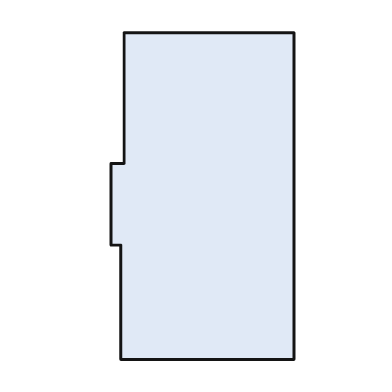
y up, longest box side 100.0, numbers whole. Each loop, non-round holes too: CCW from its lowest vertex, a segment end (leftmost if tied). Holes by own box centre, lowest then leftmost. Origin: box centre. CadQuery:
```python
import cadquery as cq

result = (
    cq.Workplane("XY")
    .moveTo(-25.0, -50.0)
    .lineTo(28.0, -50.0)
    .lineTo(28.0, 50.0)
    .lineTo(-24.0, 50.0)
    .lineTo(-24.0, 10.0)
    .lineTo(-28.0, 10.0)
    .lineTo(-28.0, -15.0)
    .lineTo(-25.0, -15.0)
    .close()
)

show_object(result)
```